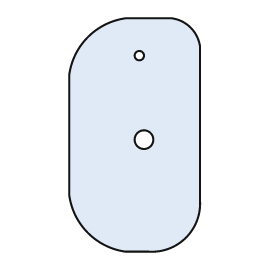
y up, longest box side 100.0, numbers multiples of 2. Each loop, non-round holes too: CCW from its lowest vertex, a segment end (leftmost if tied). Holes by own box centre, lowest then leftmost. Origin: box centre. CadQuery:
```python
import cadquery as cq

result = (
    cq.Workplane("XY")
    .moveTo(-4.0, -50.0)
    .lineTo(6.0, -50.0)
    .threePointArc((22.0, -44.0), (28.0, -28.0))
    .lineTo(28.0, 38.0)
    .threePointArc((24.0, 46.0), (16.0, 50.0))
    .lineTo(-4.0, 50.0)
    .threePointArc((-20.0, 42.0), (-28.0, 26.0))
    .lineTo(-28.0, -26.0)
    .threePointArc((-20.0, -42.0), (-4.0, -50.0))
    .close()
    .moveTo(4.0, -2.0)
    .circle(4.0)
    .moveTo(2.0, 34.0)
    .circle(2.0)
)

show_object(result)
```